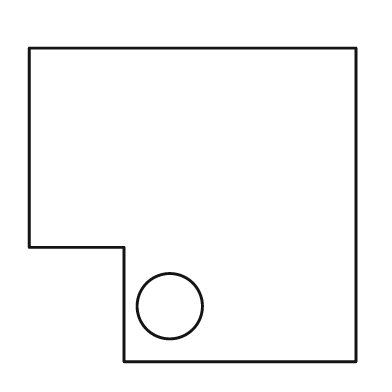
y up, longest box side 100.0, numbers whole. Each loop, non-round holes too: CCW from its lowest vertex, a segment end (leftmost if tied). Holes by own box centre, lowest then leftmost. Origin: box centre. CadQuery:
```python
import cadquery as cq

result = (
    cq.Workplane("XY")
    .moveTo(-21.0, -48.0)
    .lineTo(50.0, -48.0)
    .lineTo(50.0, 48.0)
    .lineTo(-50.0, 48.0)
    .lineTo(-50.0, -13.0)
    .lineTo(-21.0, -13.0)
    .close()
    .moveTo(-7.0, -31.0)
    .circle(10.0)
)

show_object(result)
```